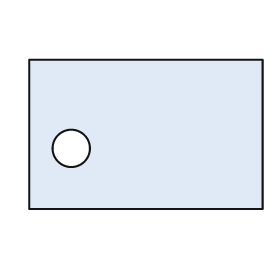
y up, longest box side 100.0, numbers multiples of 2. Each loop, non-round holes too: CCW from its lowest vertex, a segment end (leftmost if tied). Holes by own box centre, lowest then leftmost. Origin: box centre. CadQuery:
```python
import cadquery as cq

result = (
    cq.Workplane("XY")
    .moveTo(-50.0, -32.0)
    .lineTo(50.0, -32.0)
    .lineTo(50.0, 32.0)
    .lineTo(-50.0, 32.0)
    .close()
    .moveTo(-32.0, -6.0)
    .circle(8.0)
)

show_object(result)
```